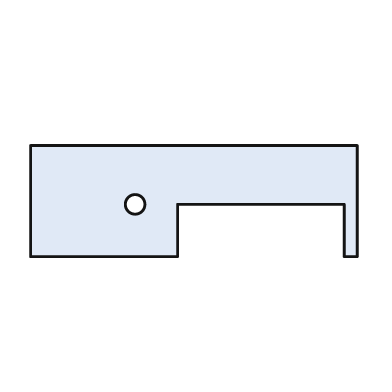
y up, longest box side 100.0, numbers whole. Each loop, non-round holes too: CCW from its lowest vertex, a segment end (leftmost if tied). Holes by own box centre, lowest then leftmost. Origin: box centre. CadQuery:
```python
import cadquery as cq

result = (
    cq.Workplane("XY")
    .moveTo(-50.0, -17.0)
    .lineTo(-5.0, -17.0)
    .lineTo(-5.0, -1.0)
    .lineTo(46.0, -1.0)
    .lineTo(46.0, -17.0)
    .lineTo(50.0, -17.0)
    .lineTo(50.0, 17.0)
    .lineTo(-50.0, 17.0)
    .close()
    .moveTo(-18.0, -1.0)
    .circle(3.0)
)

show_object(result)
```